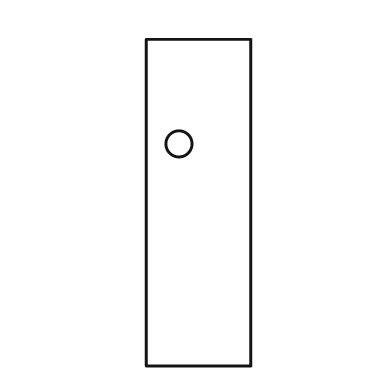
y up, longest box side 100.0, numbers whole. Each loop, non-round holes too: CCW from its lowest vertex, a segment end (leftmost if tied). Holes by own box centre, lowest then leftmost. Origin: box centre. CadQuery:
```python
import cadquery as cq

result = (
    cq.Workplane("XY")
    .moveTo(-16.0, -50.0)
    .lineTo(16.0, -50.0)
    .lineTo(16.0, 50.0)
    .lineTo(-16.0, 50.0)
    .close()
    .moveTo(-6.0, 18.0)
    .circle(4.0)
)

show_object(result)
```